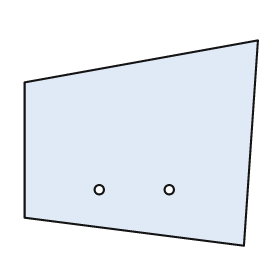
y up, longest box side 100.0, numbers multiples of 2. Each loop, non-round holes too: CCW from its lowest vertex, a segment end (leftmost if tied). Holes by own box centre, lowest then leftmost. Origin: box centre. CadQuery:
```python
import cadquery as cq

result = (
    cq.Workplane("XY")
    .moveTo(44.0, -44.0)
    .lineTo(50.0, 44.0)
    .lineTo(-50.0, 26.0)
    .lineTo(-50.0, -32.0)
    .close()
    .moveTo(-18.0, -20.0)
    .circle(2.0)
    .moveTo(12.0, -20.0)
    .circle(2.0)
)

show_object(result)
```